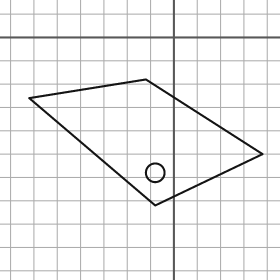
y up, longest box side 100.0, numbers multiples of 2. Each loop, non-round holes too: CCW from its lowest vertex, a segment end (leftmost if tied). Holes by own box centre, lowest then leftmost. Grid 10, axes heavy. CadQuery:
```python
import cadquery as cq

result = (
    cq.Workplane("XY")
    .moveTo(-8.0, -72.0)
    .lineTo(38.0, -50.0)
    .lineTo(-12.0, -18.0)
    .lineTo(-62.0, -26.0)
    .close()
    .moveTo(-8.0, -58.0)
    .circle(4.0)
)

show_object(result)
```